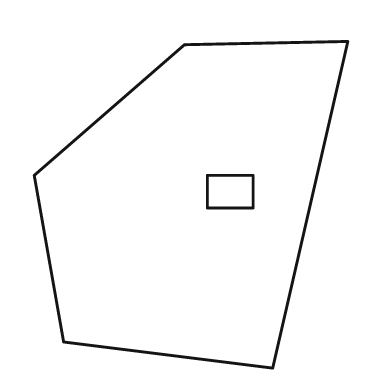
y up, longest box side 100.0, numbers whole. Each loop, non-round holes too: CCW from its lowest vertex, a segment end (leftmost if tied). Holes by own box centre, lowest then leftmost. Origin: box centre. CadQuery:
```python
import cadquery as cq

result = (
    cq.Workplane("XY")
    .moveTo(25.0, -50.0)
    .lineTo(48.0, 50.0)
    .lineTo(-2.0, 49.0)
    .lineTo(-48.0, 9.0)
    .lineTo(-39.0, -42.0)
    .close()
    .moveTo(5.0, -1.0)
    .lineTo(19.0, -1.0)
    .lineTo(19.0, 9.0)
    .lineTo(5.0, 9.0)
    .close()
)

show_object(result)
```